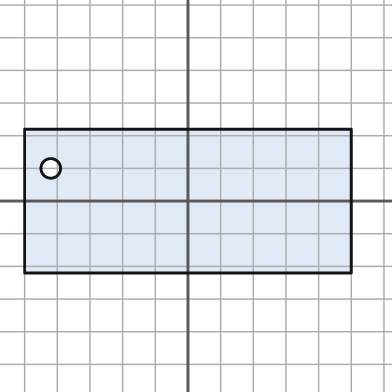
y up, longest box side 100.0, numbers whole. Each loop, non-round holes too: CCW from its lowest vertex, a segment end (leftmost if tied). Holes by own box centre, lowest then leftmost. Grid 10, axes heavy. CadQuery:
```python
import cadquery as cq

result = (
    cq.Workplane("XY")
    .moveTo(-50.0, -22.0)
    .lineTo(50.0, -22.0)
    .lineTo(50.0, 22.0)
    .lineTo(-50.0, 22.0)
    .close()
    .moveTo(-42.0, 10.0)
    .circle(3.0)
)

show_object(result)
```